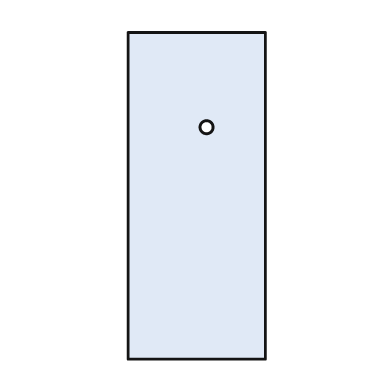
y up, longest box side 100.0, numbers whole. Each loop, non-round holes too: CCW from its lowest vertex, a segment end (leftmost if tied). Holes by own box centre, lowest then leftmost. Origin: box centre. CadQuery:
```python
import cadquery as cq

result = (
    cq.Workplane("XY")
    .moveTo(-21.0, -50.0)
    .lineTo(21.0, -50.0)
    .lineTo(21.0, 50.0)
    .lineTo(-21.0, 50.0)
    .close()
    .moveTo(3.0, 21.0)
    .circle(2.0)
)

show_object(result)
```